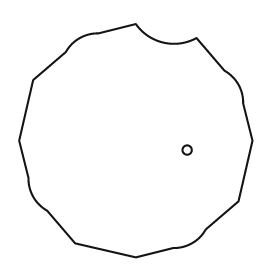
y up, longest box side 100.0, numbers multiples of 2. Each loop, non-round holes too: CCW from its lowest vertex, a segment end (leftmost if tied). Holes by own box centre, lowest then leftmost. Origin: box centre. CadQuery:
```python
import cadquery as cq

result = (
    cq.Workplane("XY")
    .moveTo(0.0, -50.0)
    .lineTo(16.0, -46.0)
    .threePointArc((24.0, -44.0), (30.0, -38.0))
    .lineTo(44.0, -26.0)
    .lineTo(50.0, 0.0)
    .lineTo(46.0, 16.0)
    .threePointArc((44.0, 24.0), (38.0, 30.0))
    .lineTo(26.0, 44.0)
    .threePointArc((12.0, 42.0), (0.0, 50.0))
    .lineTo(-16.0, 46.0)
    .threePointArc((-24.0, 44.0), (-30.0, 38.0))
    .lineTo(-44.0, 26.0)
    .lineTo(-50.0, 0.0)
    .lineTo(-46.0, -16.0)
    .threePointArc((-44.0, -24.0), (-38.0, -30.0))
    .lineTo(-26.0, -44.0)
    .close()
    .moveTo(22.0, -4.0)
    .circle(2.0)
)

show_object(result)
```